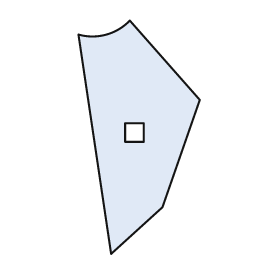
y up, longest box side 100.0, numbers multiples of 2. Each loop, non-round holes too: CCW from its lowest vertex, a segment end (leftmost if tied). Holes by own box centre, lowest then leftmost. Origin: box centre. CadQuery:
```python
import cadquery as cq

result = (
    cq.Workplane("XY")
    .moveTo(-12.0, -50.0)
    .lineTo(10.0, -30.0)
    .lineTo(26.0, 16.0)
    .lineTo(-4.0, 50.0)
    .threePointArc((-14.0, 44.0), (-26.0, 44.0))
    .close()
    .moveTo(-6.0, -2.0)
    .lineTo(2.0, -2.0)
    .lineTo(2.0, 6.0)
    .lineTo(-6.0, 6.0)
    .close()
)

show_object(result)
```